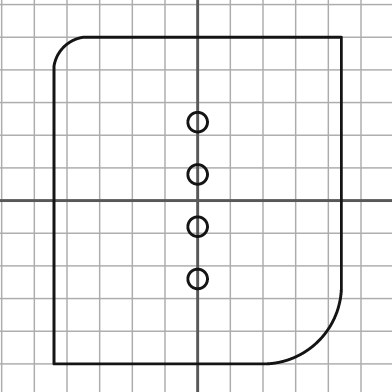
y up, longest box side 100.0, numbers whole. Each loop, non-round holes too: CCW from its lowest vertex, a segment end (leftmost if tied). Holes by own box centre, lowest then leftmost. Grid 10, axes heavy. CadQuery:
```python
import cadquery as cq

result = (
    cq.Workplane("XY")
    .moveTo(-44.0, -50.0)
    .lineTo(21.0, -50.0)
    .threePointArc((37.0, -43.0), (44.0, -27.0))
    .lineTo(44.0, 50.0)
    .lineTo(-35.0, 50.0)
    .threePointArc((-41.0, 47.0), (-44.0, 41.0))
    .close()
    .moveTo(0.0, -24.0)
    .circle(3.0)
    .moveTo(0.0, -8.0)
    .circle(3.0)
    .moveTo(0.0, 8.0)
    .circle(3.0)
    .moveTo(0.0, 24.0)
    .circle(3.0)
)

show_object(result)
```